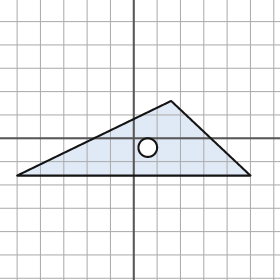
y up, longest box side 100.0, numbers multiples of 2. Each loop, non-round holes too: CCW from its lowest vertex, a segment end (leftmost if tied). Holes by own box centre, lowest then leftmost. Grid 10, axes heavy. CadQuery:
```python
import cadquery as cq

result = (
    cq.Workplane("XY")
    .moveTo(-50.0, -16.0)
    .lineTo(50.0, -16.0)
    .lineTo(16.0, 16.0)
    .close()
    .moveTo(6.0, -4.0)
    .circle(4.0)
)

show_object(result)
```